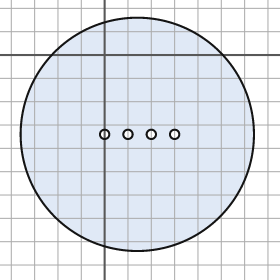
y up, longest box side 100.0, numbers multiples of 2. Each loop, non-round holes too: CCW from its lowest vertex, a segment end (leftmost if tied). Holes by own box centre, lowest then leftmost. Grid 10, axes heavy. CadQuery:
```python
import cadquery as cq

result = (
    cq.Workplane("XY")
    .moveTo(14.0, -34.0)
    .circle(50.0)
    .moveTo(0.0, -34.0)
    .circle(2.0)
    .moveTo(10.0, -34.0)
    .circle(2.0)
    .moveTo(20.0, -34.0)
    .circle(2.0)
    .moveTo(30.0, -34.0)
    .circle(2.0)
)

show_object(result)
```